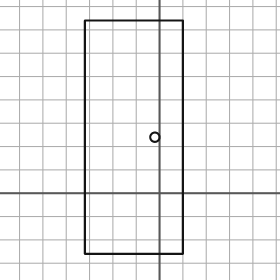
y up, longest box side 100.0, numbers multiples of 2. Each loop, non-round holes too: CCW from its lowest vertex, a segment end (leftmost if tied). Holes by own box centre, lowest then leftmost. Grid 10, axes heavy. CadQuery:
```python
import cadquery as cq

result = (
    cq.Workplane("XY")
    .moveTo(-32.0, -26.0)
    .lineTo(10.0, -26.0)
    .lineTo(10.0, 74.0)
    .lineTo(-32.0, 74.0)
    .close()
    .moveTo(-2.0, 24.0)
    .circle(2.0)
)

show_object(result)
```